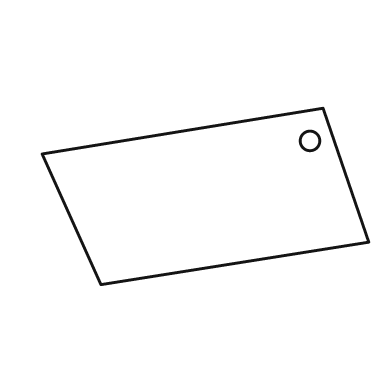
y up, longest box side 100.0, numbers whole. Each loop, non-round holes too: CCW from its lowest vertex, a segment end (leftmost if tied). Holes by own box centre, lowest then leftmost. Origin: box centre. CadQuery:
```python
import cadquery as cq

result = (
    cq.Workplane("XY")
    .moveTo(-32.0, -27.0)
    .lineTo(50.0, -14.0)
    .lineTo(36.0, 27.0)
    .lineTo(-50.0, 13.0)
    .close()
    .moveTo(32.0, 17.0)
    .circle(3.0)
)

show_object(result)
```